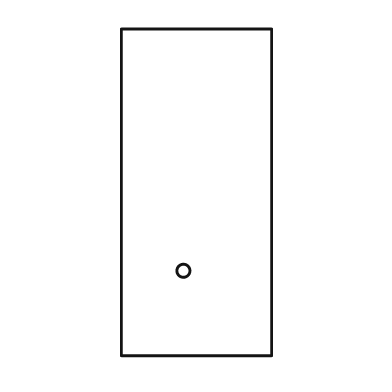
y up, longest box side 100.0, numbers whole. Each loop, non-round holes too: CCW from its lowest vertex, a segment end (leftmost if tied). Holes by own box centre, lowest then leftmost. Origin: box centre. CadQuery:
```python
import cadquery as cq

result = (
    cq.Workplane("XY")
    .moveTo(-23.0, -50.0)
    .lineTo(23.0, -50.0)
    .lineTo(23.0, 50.0)
    .lineTo(-23.0, 50.0)
    .close()
    .moveTo(-4.0, -24.0)
    .circle(2.0)
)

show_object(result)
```